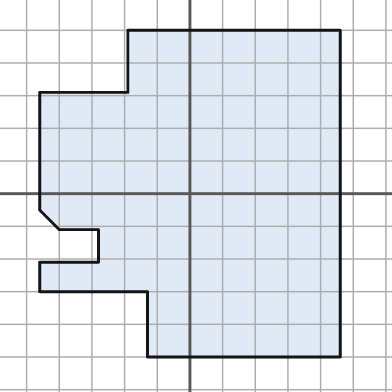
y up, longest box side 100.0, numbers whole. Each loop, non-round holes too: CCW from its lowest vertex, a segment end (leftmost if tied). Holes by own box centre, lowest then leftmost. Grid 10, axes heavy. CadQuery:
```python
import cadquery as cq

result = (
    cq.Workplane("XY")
    .moveTo(-13.0, -50.0)
    .lineTo(46.0, -50.0)
    .lineTo(46.0, 50.0)
    .lineTo(-19.0, 50.0)
    .lineTo(-19.0, 31.0)
    .lineTo(-46.0, 31.0)
    .lineTo(-46.0, -5.0)
    .lineTo(-40.0, -11.0)
    .lineTo(-28.0, -11.0)
    .lineTo(-28.0, -21.0)
    .lineTo(-46.0, -21.0)
    .lineTo(-46.0, -30.0)
    .lineTo(-13.0, -30.0)
    .close()
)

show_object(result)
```